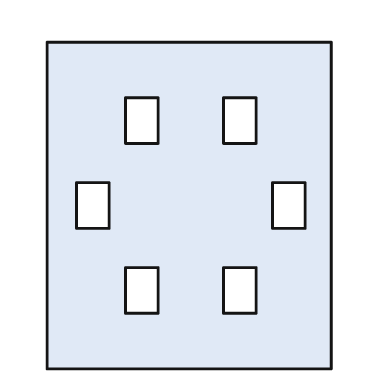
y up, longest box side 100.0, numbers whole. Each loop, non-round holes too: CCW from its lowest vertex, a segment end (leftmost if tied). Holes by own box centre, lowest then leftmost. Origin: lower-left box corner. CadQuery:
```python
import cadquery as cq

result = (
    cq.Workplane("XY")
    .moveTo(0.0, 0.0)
    .lineTo(87.0, 0.0)
    .lineTo(87.0, 100.0)
    .lineTo(0.0, 100.0)
    .close()
    .moveTo(24.0, 17.0)
    .lineTo(34.0, 17.0)
    .lineTo(34.0, 31.0)
    .lineTo(24.0, 31.0)
    .close()
    .moveTo(54.0, 17.0)
    .lineTo(64.0, 17.0)
    .lineTo(64.0, 31.0)
    .lineTo(54.0, 31.0)
    .close()
    .moveTo(9.0, 43.0)
    .lineTo(19.0, 43.0)
    .lineTo(19.0, 57.0)
    .lineTo(9.0, 57.0)
    .close()
    .moveTo(69.0, 43.0)
    .lineTo(79.0, 43.0)
    .lineTo(79.0, 57.0)
    .lineTo(69.0, 57.0)
    .close()
    .moveTo(24.0, 69.0)
    .lineTo(34.0, 69.0)
    .lineTo(34.0, 83.0)
    .lineTo(24.0, 83.0)
    .close()
    .moveTo(54.0, 69.0)
    .lineTo(64.0, 69.0)
    .lineTo(64.0, 83.0)
    .lineTo(54.0, 83.0)
    .close()
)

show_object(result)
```